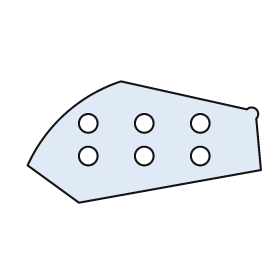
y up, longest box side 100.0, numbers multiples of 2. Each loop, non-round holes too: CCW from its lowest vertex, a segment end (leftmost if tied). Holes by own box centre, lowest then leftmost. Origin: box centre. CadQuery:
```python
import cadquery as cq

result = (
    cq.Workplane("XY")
    .moveTo(-28.0, -26.0)
    .lineTo(50.0, -12.0)
    .lineTo(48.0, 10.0)
    .threePointArc((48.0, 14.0), (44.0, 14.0))
    .lineTo(-10.0, 26.0)
    .threePointArc((-34.0, 12.0), (-50.0, -10.0))
    .close()
    .moveTo(-24.0, -6.0)
    .circle(4.0)
    .moveTo(0.0, -6.0)
    .circle(4.0)
    .moveTo(24.0, -6.0)
    .circle(4.0)
    .moveTo(-24.0, 8.0)
    .circle(4.0)
    .moveTo(0.0, 8.0)
    .circle(4.0)
    .moveTo(24.0, 8.0)
    .circle(4.0)
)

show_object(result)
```